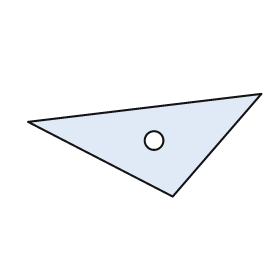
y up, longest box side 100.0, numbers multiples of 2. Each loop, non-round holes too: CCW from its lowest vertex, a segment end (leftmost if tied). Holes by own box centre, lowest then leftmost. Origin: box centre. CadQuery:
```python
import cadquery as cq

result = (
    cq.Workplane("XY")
    .moveTo(12.0, -22.0)
    .lineTo(50.0, 22.0)
    .lineTo(-50.0, 10.0)
    .close()
    .moveTo(4.0, 2.0)
    .circle(4.0)
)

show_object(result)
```